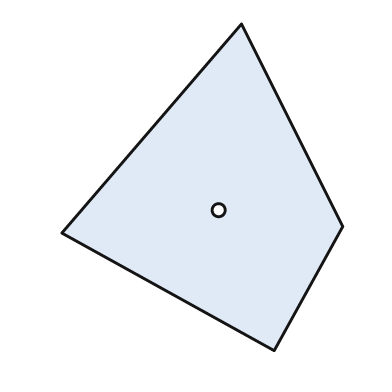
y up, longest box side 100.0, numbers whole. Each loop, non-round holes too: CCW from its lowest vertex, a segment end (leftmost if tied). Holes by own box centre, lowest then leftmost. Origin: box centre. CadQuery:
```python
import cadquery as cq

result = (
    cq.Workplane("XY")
    .moveTo(22.0, -50.0)
    .lineTo(43.0, -12.0)
    .lineTo(12.0, 50.0)
    .lineTo(-43.0, -14.0)
    .close()
    .moveTo(5.0, -7.0)
    .circle(2.0)
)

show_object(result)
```